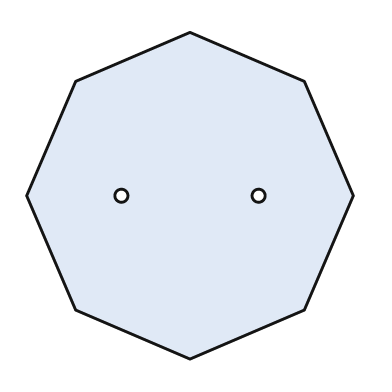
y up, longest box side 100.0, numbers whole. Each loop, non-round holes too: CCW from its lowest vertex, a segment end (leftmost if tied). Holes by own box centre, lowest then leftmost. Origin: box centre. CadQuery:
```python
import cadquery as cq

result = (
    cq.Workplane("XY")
    .moveTo(0.0, -50.0)
    .lineTo(35.0, -35.0)
    .lineTo(50.0, 0.0)
    .lineTo(35.0, 35.0)
    .lineTo(0.0, 50.0)
    .lineTo(-35.0, 35.0)
    .lineTo(-50.0, 0.0)
    .lineTo(-35.0, -35.0)
    .close()
    .moveTo(-21.0, 0.0)
    .circle(2.0)
    .moveTo(21.0, 0.0)
    .circle(2.0)
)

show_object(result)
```